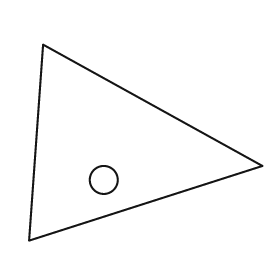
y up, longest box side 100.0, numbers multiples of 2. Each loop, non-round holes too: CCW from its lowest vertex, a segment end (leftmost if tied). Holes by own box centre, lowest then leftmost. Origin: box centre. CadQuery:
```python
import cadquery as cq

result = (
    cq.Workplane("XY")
    .moveTo(-50.0, -42.0)
    .lineTo(50.0, -10.0)
    .lineTo(-44.0, 42.0)
    .close()
    .moveTo(-18.0, -16.0)
    .circle(6.0)
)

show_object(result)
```